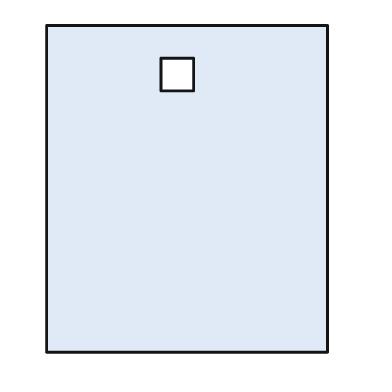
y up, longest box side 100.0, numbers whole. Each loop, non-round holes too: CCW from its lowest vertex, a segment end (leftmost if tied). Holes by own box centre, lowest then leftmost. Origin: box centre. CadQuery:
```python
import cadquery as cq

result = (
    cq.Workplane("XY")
    .moveTo(-43.0, -50.0)
    .lineTo(43.0, -50.0)
    .lineTo(43.0, 50.0)
    .lineTo(-43.0, 50.0)
    .close()
    .moveTo(-8.0, 30.0)
    .lineTo(2.0, 30.0)
    .lineTo(2.0, 40.0)
    .lineTo(-8.0, 40.0)
    .close()
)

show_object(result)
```